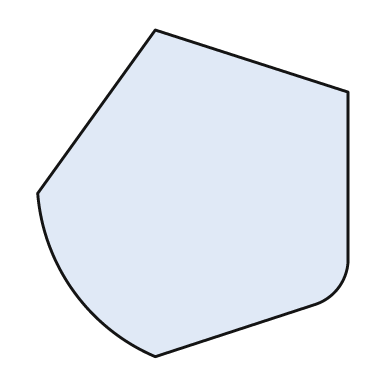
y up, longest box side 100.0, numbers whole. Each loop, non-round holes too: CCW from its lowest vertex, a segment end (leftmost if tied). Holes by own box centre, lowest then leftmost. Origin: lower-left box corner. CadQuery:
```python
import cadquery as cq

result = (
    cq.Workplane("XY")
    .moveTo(36.0, 0.0)
    .lineTo(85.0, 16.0)
    .threePointArc((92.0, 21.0), (95.0, 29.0))
    .lineTo(95.0, 81.0)
    .lineTo(36.0, 100.0)
    .lineTo(0.0, 50.0)
    .threePointArc((11.0, 20.0), (36.0, 0.0))
    .close()
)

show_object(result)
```